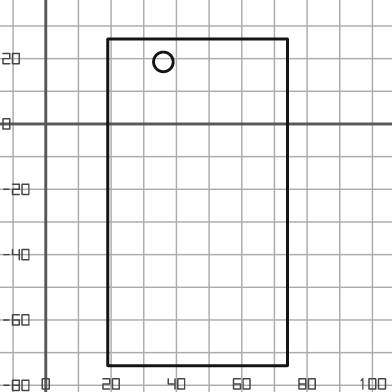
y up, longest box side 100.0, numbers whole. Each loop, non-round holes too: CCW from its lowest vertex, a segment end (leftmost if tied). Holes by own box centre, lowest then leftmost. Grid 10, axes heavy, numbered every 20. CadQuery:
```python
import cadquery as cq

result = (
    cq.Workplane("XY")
    .moveTo(19.0, -74.0)
    .lineTo(74.0, -74.0)
    .lineTo(74.0, 26.0)
    .lineTo(19.0, 26.0)
    .close()
    .moveTo(36.0, 19.0)
    .circle(3.0)
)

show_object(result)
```